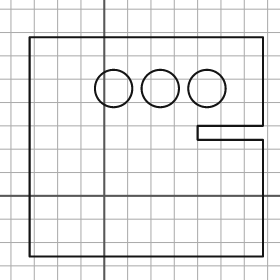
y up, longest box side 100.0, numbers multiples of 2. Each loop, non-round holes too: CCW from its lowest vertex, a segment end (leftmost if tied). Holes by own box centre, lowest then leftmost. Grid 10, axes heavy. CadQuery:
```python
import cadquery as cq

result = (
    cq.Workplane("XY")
    .moveTo(-32.0, -26.0)
    .lineTo(68.0, -26.0)
    .lineTo(68.0, 24.0)
    .lineTo(40.0, 24.0)
    .lineTo(40.0, 30.0)
    .lineTo(68.0, 30.0)
    .lineTo(68.0, 68.0)
    .lineTo(-32.0, 68.0)
    .close()
    .moveTo(4.0, 46.0)
    .circle(8.0)
    .moveTo(24.0, 46.0)
    .circle(8.0)
    .moveTo(44.0, 46.0)
    .circle(8.0)
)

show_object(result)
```